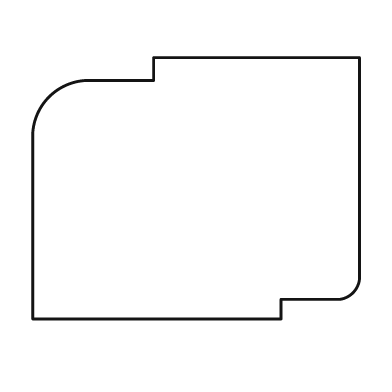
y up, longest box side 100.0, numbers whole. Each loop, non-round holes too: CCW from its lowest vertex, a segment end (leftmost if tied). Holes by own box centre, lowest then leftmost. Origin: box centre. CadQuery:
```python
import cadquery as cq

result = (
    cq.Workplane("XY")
    .moveTo(-50.0, -40.0)
    .lineTo(26.0, -40.0)
    .lineTo(26.0, -34.0)
    .lineTo(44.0, -34.0)
    .threePointArc((48.0, -32.0), (50.0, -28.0))
    .lineTo(50.0, 40.0)
    .lineTo(-13.0, 40.0)
    .lineTo(-13.0, 33.0)
    .lineTo(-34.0, 33.0)
    .threePointArc((-45.0, 28.0), (-50.0, 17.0))
    .close()
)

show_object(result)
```